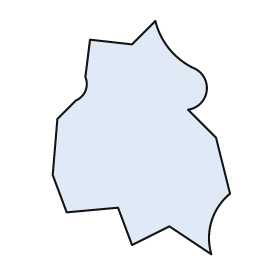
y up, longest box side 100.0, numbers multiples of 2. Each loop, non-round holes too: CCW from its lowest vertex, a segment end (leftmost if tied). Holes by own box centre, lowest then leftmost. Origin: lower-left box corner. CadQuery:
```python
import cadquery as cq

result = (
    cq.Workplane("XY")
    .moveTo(68.0, 0.0)
    .threePointArc((68.0, 14.0), (76.0, 26.0))
    .lineTo(70.0, 50.0)
    .lineTo(58.0, 62.0)
    .threePointArc((66.0, 70.0), (60.0, 80.0))
    .threePointArc((50.0, 88.0), (44.0, 100.0))
    .lineTo(34.0, 90.0)
    .lineTo(16.0, 92.0)
    .lineTo(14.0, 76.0)
    .threePointArc((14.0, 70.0), (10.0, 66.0))
    .lineTo(2.0, 58.0)
    .lineTo(0.0, 34.0)
    .lineTo(6.0, 18.0)
    .lineTo(28.0, 20.0)
    .lineTo(34.0, 4.0)
    .lineTo(50.0, 12.0)
    .close()
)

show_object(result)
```